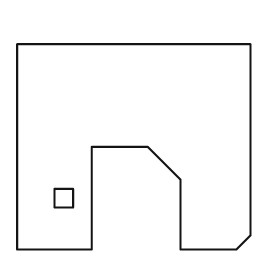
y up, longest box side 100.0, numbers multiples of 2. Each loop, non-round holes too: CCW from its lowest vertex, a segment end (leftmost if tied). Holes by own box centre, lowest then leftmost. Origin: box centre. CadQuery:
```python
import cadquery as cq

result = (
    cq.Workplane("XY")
    .moveTo(-50.0, -44.0)
    .lineTo(-18.0, -44.0)
    .lineTo(-18.0, 0.0)
    .lineTo(6.0, 0.0)
    .lineTo(20.0, -14.0)
    .lineTo(20.0, -44.0)
    .lineTo(44.0, -44.0)
    .lineTo(50.0, -38.0)
    .lineTo(50.0, 44.0)
    .lineTo(-50.0, 44.0)
    .close()
    .moveTo(-34.0, -26.0)
    .lineTo(-26.0, -26.0)
    .lineTo(-26.0, -18.0)
    .lineTo(-34.0, -18.0)
    .close()
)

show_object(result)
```